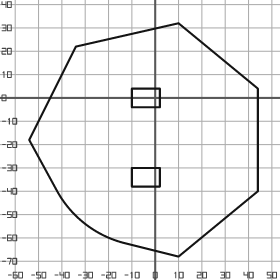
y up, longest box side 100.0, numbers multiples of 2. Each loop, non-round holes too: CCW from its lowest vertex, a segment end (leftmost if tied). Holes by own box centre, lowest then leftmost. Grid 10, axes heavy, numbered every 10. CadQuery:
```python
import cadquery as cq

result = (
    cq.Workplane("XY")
    .moveTo(10.0, -68.0)
    .lineTo(44.0, -40.0)
    .lineTo(44.0, 4.0)
    .lineTo(10.0, 32.0)
    .lineTo(-34.0, 22.0)
    .lineTo(-54.0, -18.0)
    .lineTo(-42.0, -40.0)
    .threePointArc((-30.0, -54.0), (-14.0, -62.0))
    .close()
    .moveTo(-10.0, -38.0)
    .lineTo(2.0, -38.0)
    .lineTo(2.0, -30.0)
    .lineTo(-10.0, -30.0)
    .close()
    .moveTo(-10.0, -4.0)
    .lineTo(2.0, -4.0)
    .lineTo(2.0, 4.0)
    .lineTo(-10.0, 4.0)
    .close()
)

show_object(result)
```